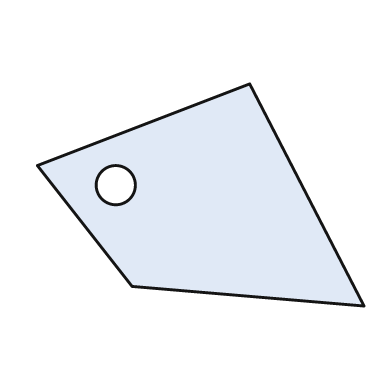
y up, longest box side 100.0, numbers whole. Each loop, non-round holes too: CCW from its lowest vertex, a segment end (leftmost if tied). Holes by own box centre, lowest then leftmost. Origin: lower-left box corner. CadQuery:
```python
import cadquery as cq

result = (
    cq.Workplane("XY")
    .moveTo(100.0, 0.0)
    .lineTo(65.0, 68.0)
    .lineTo(0.0, 43.0)
    .lineTo(29.0, 6.0)
    .close()
    .moveTo(24.0, 37.0)
    .circle(6.0)
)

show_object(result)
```